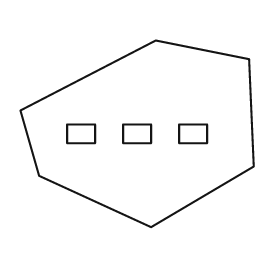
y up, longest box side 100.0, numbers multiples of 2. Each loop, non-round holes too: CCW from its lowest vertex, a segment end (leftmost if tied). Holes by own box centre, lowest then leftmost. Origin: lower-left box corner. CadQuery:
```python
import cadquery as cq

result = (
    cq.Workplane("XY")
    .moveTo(56.0, 0.0)
    .lineTo(100.0, 26.0)
    .lineTo(98.0, 72.0)
    .lineTo(58.0, 80.0)
    .lineTo(0.0, 50.0)
    .lineTo(8.0, 22.0)
    .close()
    .moveTo(20.0, 36.0)
    .lineTo(32.0, 36.0)
    .lineTo(32.0, 44.0)
    .lineTo(20.0, 44.0)
    .close()
    .moveTo(44.0, 36.0)
    .lineTo(56.0, 36.0)
    .lineTo(56.0, 44.0)
    .lineTo(44.0, 44.0)
    .close()
    .moveTo(68.0, 36.0)
    .lineTo(80.0, 36.0)
    .lineTo(80.0, 44.0)
    .lineTo(68.0, 44.0)
    .close()
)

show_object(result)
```